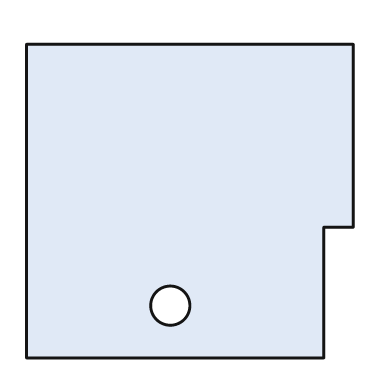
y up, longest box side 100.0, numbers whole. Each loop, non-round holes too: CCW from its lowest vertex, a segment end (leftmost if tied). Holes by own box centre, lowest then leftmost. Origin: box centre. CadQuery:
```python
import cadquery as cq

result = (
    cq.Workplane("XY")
    .moveTo(-50.0, -48.0)
    .lineTo(41.0, -48.0)
    .lineTo(41.0, -8.0)
    .lineTo(50.0, -8.0)
    .lineTo(50.0, 48.0)
    .lineTo(-50.0, 48.0)
    .close()
    .moveTo(-6.0, -32.0)
    .circle(6.0)
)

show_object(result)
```